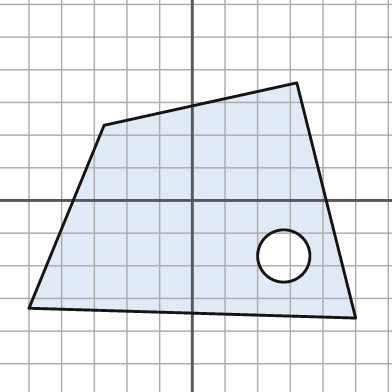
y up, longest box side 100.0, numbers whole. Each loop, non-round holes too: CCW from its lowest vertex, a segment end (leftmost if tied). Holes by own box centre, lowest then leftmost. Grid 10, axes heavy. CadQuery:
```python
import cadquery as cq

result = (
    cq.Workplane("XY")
    .moveTo(50.0, -36.0)
    .lineTo(32.0, 36.0)
    .lineTo(-27.0, 23.0)
    .lineTo(-50.0, -33.0)
    .close()
    .moveTo(28.0, -17.0)
    .circle(8.0)
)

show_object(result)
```